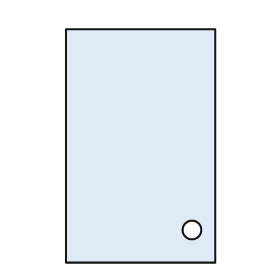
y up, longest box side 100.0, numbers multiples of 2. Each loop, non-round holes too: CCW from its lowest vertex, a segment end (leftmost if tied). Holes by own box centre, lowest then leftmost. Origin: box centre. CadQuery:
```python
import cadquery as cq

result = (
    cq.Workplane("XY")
    .moveTo(-32.0, -50.0)
    .lineTo(32.0, -50.0)
    .lineTo(32.0, 50.0)
    .lineTo(-32.0, 50.0)
    .close()
    .moveTo(22.0, -36.0)
    .circle(4.0)
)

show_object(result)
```